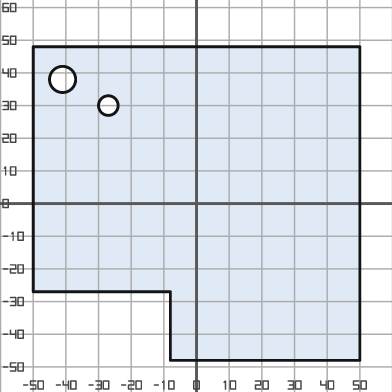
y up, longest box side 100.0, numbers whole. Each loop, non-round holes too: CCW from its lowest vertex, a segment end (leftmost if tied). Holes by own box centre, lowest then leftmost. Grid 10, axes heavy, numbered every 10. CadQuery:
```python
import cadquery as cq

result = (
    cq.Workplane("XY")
    .moveTo(-8.0, -48.0)
    .lineTo(50.0, -48.0)
    .lineTo(50.0, 48.0)
    .lineTo(-50.0, 48.0)
    .lineTo(-50.0, -27.0)
    .lineTo(-8.0, -27.0)
    .close()
    .moveTo(-27.0, 30.0)
    .circle(3.0)
    .moveTo(-41.0, 38.0)
    .circle(4.0)
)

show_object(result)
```